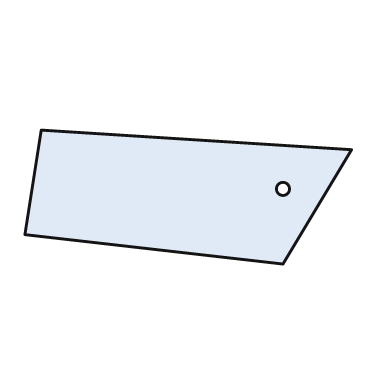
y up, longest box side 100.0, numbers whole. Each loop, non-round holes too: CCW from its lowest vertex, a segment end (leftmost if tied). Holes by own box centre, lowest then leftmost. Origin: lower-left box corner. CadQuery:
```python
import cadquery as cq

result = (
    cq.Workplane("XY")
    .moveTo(79.0, 0.0)
    .lineTo(100.0, 35.0)
    .lineTo(5.0, 41.0)
    .lineTo(0.0, 9.0)
    .close()
    .moveTo(79.0, 23.0)
    .circle(2.0)
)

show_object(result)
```